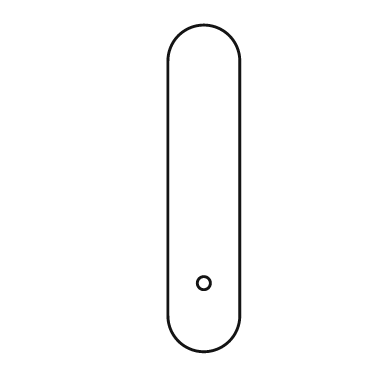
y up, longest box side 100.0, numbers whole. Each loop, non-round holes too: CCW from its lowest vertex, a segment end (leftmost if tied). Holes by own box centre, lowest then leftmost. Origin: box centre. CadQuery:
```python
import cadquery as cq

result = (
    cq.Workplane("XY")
    .moveTo(-11.0, -39.0)
    .threePointArc((0.0, -50.0), (11.0, -39.0))
    .lineTo(11.0, 39.0)
    .threePointArc((0.0, 50.0), (-11.0, 39.0))
    .close()
    .moveTo(0.0, -29.0)
    .circle(2.0)
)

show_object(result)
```